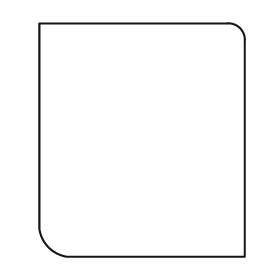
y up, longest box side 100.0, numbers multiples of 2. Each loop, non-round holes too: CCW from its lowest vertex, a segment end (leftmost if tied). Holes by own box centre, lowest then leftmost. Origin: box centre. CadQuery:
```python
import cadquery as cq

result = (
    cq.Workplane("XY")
    .moveTo(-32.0, -50.0)
    .lineTo(44.0, -50.0)
    .lineTo(44.0, 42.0)
    .threePointArc((42.0, 48.0), (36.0, 50.0))
    .lineTo(-44.0, 50.0)
    .lineTo(-44.0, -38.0)
    .threePointArc((-40.0, -46.0), (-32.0, -50.0))
    .close()
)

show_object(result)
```